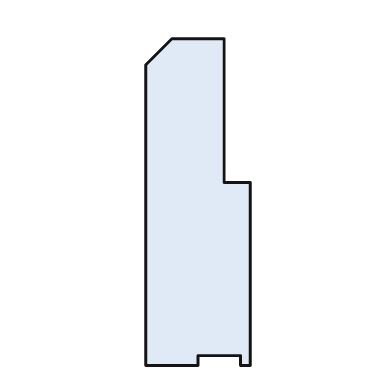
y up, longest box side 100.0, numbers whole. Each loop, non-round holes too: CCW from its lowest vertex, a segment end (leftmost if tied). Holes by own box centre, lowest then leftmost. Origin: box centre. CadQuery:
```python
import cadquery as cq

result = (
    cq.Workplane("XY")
    .moveTo(-16.0, -50.0)
    .lineTo(0.0, -50.0)
    .lineTo(0.0, -47.0)
    .lineTo(13.0, -47.0)
    .lineTo(13.0, -50.0)
    .lineTo(16.0, -50.0)
    .lineTo(16.0, 6.0)
    .lineTo(8.0, 6.0)
    .lineTo(8.0, 50.0)
    .lineTo(-8.0, 50.0)
    .lineTo(-16.0, 42.0)
    .close()
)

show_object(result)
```